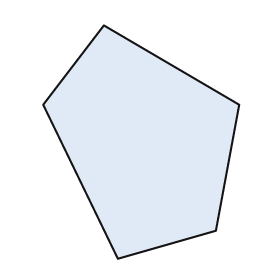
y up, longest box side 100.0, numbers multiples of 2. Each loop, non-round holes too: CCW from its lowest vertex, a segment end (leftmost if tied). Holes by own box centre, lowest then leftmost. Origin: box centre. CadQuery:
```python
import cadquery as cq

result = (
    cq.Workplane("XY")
    .moveTo(-10.0, -50.0)
    .lineTo(32.0, -38.0)
    .lineTo(42.0, 16.0)
    .lineTo(-16.0, 50.0)
    .lineTo(-42.0, 16.0)
    .close()
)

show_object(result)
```